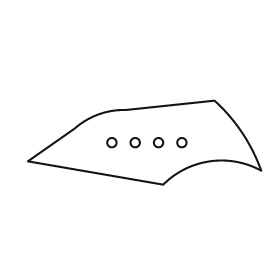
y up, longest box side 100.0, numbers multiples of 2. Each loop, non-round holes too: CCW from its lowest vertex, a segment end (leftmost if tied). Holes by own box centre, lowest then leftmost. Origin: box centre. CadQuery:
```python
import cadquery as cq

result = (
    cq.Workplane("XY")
    .moveTo(8.0, -18.0)
    .threePointArc((28.0, -8.0), (50.0, -12.0))
    .threePointArc((42.0, 4.0), (30.0, 18.0))
    .lineTo(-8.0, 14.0)
    .threePointArc((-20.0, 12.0), (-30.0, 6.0))
    .lineTo(-50.0, -8.0)
    .close()
    .moveTo(-14.0, 0.0)
    .circle(2.0)
    .moveTo(-4.0, 0.0)
    .circle(2.0)
    .moveTo(6.0, 0.0)
    .circle(2.0)
    .moveTo(16.0, 0.0)
    .circle(2.0)
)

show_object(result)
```